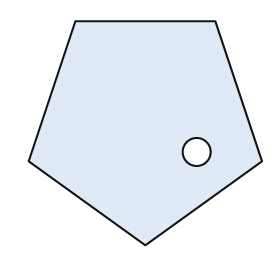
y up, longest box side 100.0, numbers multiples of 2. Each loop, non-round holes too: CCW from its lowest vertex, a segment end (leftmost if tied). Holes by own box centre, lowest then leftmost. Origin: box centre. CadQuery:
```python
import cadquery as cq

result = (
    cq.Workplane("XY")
    .moveTo(0.0, -48.0)
    .lineTo(50.0, -12.0)
    .lineTo(30.0, 48.0)
    .lineTo(-30.0, 48.0)
    .lineTo(-50.0, -12.0)
    .close()
    .moveTo(22.0, -8.0)
    .circle(6.0)
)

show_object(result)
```